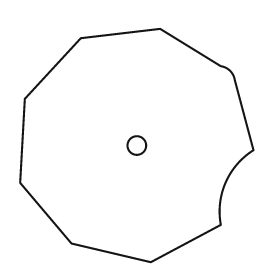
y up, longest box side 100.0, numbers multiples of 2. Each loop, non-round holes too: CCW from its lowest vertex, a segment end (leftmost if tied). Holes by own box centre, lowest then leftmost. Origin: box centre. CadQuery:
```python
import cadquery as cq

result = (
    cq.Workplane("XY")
    .moveTo(6.0, -50.0)
    .lineTo(36.0, -34.0)
    .threePointArc((38.0, -16.0), (50.0, -2.0))
    .lineTo(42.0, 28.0)
    .threePointArc((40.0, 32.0), (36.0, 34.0))
    .lineTo(10.0, 50.0)
    .lineTo(-24.0, 46.0)
    .lineTo(-48.0, 20.0)
    .lineTo(-50.0, -16.0)
    .lineTo(-28.0, -42.0)
    .close()
    .moveTo(0.0, 0.0)
    .circle(4.0)
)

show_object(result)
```